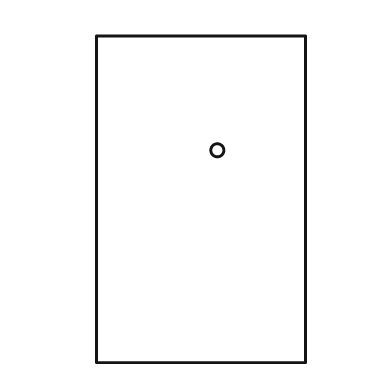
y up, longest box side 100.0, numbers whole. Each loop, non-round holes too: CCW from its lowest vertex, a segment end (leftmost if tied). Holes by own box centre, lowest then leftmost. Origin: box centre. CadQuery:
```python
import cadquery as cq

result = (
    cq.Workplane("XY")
    .moveTo(-32.0, -50.0)
    .lineTo(32.0, -50.0)
    .lineTo(32.0, 50.0)
    .lineTo(-32.0, 50.0)
    .close()
    .moveTo(5.0, 15.0)
    .circle(2.0)
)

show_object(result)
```